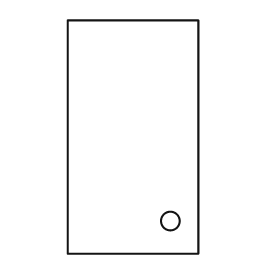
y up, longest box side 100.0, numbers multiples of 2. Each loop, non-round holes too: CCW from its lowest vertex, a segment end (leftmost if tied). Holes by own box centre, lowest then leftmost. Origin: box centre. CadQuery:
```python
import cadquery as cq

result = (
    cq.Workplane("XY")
    .moveTo(-28.0, -50.0)
    .lineTo(28.0, -50.0)
    .lineTo(28.0, 50.0)
    .lineTo(-28.0, 50.0)
    .close()
    .moveTo(16.0, -36.0)
    .circle(4.0)
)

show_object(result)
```